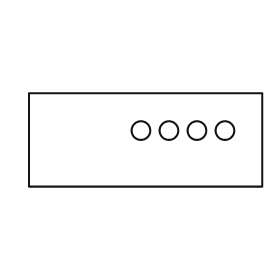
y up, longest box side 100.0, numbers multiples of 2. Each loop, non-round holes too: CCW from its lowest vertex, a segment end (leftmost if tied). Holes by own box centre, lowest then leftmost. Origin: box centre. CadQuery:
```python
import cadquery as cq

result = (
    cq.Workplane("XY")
    .moveTo(-50.0, -20.0)
    .lineTo(50.0, -20.0)
    .lineTo(50.0, 20.0)
    .lineTo(-50.0, 20.0)
    .close()
    .moveTo(-2.0, 4.0)
    .circle(4.0)
    .moveTo(10.0, 4.0)
    .circle(4.0)
    .moveTo(22.0, 4.0)
    .circle(4.0)
    .moveTo(34.0, 4.0)
    .circle(4.0)
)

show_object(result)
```